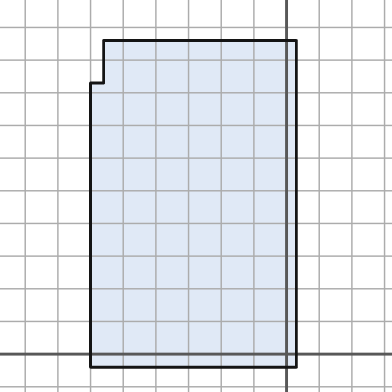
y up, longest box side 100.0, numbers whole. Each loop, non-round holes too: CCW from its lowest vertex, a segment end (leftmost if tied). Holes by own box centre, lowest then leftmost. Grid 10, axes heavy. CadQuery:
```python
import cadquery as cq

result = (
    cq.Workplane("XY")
    .moveTo(-60.0, -4.0)
    .lineTo(3.0, -4.0)
    .lineTo(3.0, 96.0)
    .lineTo(-56.0, 96.0)
    .lineTo(-56.0, 83.0)
    .lineTo(-60.0, 83.0)
    .close()
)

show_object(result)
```